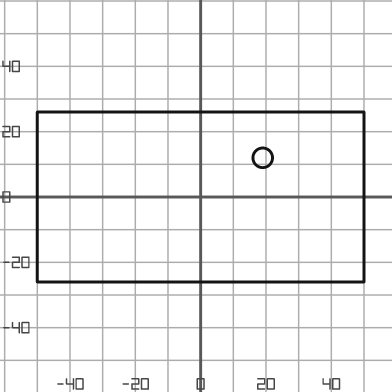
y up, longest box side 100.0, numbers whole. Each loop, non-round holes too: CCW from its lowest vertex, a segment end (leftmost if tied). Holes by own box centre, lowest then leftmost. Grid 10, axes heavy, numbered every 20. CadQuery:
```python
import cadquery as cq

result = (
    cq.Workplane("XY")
    .moveTo(-50.0, -26.0)
    .lineTo(50.0, -26.0)
    .lineTo(50.0, 26.0)
    .lineTo(-50.0, 26.0)
    .close()
    .moveTo(19.0, 12.0)
    .circle(3.0)
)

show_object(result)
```